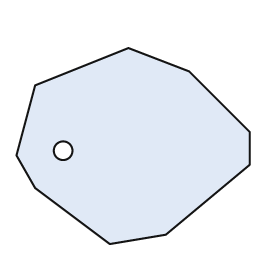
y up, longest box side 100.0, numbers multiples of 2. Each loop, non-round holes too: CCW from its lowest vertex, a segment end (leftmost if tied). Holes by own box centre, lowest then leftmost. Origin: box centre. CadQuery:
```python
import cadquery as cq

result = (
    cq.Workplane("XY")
    .moveTo(-10.0, -42.0)
    .lineTo(14.0, -38.0)
    .lineTo(50.0, -8.0)
    .lineTo(50.0, 6.0)
    .lineTo(24.0, 32.0)
    .lineTo(-2.0, 42.0)
    .lineTo(-42.0, 26.0)
    .lineTo(-50.0, -4.0)
    .lineTo(-42.0, -18.0)
    .close()
    .moveTo(-30.0, -2.0)
    .circle(4.0)
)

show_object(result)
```